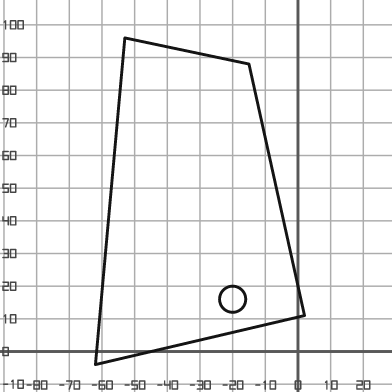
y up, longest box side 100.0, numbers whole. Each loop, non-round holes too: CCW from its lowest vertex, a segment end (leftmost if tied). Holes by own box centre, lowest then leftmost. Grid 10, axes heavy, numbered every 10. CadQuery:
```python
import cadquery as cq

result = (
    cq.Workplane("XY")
    .moveTo(-62.0, -4.0)
    .lineTo(2.0, 11.0)
    .lineTo(-15.0, 88.0)
    .lineTo(-53.0, 96.0)
    .close()
    .moveTo(-20.0, 16.0)
    .circle(4.0)
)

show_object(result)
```